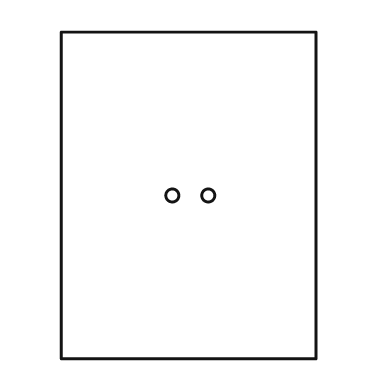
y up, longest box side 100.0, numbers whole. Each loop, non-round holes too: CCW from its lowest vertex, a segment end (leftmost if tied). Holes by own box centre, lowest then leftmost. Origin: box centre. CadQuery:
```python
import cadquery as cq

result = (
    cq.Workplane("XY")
    .moveTo(-39.0, -50.0)
    .lineTo(39.0, -50.0)
    .lineTo(39.0, 50.0)
    .lineTo(-39.0, 50.0)
    .close()
    .moveTo(-5.0, 0.0)
    .circle(2.0)
    .moveTo(6.0, 0.0)
    .circle(2.0)
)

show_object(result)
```